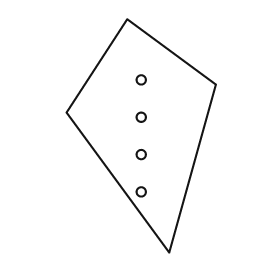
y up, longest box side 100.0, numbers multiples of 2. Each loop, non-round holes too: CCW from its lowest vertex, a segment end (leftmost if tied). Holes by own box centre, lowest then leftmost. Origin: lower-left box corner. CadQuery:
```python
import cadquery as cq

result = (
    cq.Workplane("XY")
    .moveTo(44.0, 0.0)
    .lineTo(64.0, 72.0)
    .lineTo(26.0, 100.0)
    .lineTo(0.0, 60.0)
    .close()
    .moveTo(32.0, 26.0)
    .circle(2.0)
    .moveTo(32.0, 42.0)
    .circle(2.0)
    .moveTo(32.0, 58.0)
    .circle(2.0)
    .moveTo(32.0, 74.0)
    .circle(2.0)
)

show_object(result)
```